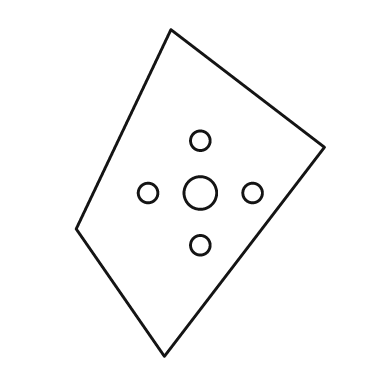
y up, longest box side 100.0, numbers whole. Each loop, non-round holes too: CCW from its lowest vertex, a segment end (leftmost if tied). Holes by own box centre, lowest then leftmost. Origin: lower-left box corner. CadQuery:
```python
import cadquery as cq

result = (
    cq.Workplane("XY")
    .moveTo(27.0, 0.0)
    .lineTo(76.0, 64.0)
    .lineTo(29.0, 100.0)
    .lineTo(0.0, 39.0)
    .close()
    .moveTo(38.0, 34.0)
    .circle(3.0)
    .moveTo(22.0, 50.0)
    .circle(3.0)
    .moveTo(38.0, 50.0)
    .circle(5.0)
    .moveTo(54.0, 50.0)
    .circle(3.0)
    .moveTo(38.0, 66.0)
    .circle(3.0)
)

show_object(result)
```